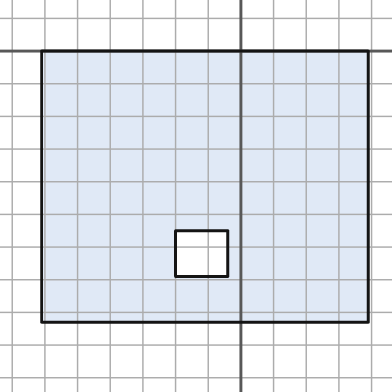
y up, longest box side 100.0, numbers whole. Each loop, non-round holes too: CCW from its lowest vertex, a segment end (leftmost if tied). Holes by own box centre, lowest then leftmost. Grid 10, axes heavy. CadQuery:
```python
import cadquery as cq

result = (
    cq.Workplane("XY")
    .moveTo(-61.0, -83.0)
    .lineTo(39.0, -83.0)
    .lineTo(39.0, 0.0)
    .lineTo(-61.0, 0.0)
    .close()
    .moveTo(-20.0, -69.0)
    .lineTo(-4.0, -69.0)
    .lineTo(-4.0, -55.0)
    .lineTo(-20.0, -55.0)
    .close()
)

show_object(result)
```